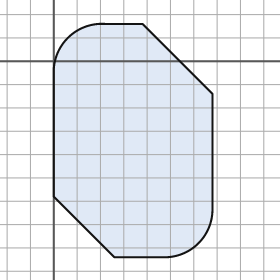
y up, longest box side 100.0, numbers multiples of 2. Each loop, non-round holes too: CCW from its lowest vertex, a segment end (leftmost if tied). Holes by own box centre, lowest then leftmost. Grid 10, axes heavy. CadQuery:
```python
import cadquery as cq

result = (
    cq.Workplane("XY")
    .moveTo(26.0, -84.0)
    .lineTo(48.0, -84.0)
    .threePointArc((62.0, -78.0), (68.0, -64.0))
    .lineTo(68.0, -14.0)
    .lineTo(38.0, 16.0)
    .lineTo(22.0, 16.0)
    .threePointArc((6.0, 10.0), (0.0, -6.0))
    .lineTo(0.0, -58.0)
    .close()
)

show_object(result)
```